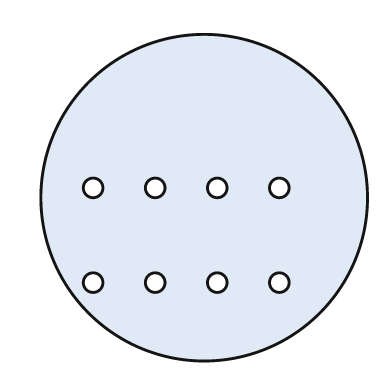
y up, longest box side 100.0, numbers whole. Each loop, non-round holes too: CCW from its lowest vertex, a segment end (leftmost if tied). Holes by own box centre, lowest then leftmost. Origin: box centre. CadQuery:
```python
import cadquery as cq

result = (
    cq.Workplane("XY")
    .moveTo(0.0, 0.0)
    .circle(50.0)
    .moveTo(-34.0, -26.0)
    .circle(3.0)
    .moveTo(-15.0, -26.0)
    .circle(3.0)
    .moveTo(4.0, -26.0)
    .circle(3.0)
    .moveTo(23.0, -26.0)
    .circle(3.0)
    .moveTo(-34.0, 3.0)
    .circle(3.0)
    .moveTo(-15.0, 3.0)
    .circle(3.0)
    .moveTo(4.0, 3.0)
    .circle(3.0)
    .moveTo(23.0, 3.0)
    .circle(3.0)
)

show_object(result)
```